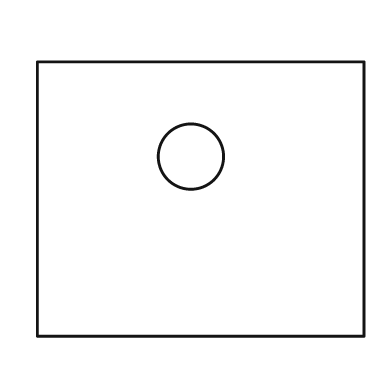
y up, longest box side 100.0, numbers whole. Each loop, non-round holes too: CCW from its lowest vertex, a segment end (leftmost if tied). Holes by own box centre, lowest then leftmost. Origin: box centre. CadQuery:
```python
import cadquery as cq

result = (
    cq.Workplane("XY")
    .moveTo(-50.0, -42.0)
    .lineTo(50.0, -42.0)
    .lineTo(50.0, 42.0)
    .lineTo(-50.0, 42.0)
    .close()
    .moveTo(-3.0, 13.0)
    .circle(10.0)
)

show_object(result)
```